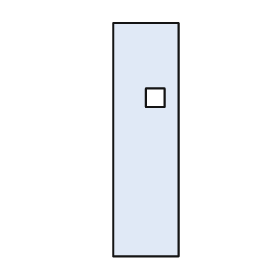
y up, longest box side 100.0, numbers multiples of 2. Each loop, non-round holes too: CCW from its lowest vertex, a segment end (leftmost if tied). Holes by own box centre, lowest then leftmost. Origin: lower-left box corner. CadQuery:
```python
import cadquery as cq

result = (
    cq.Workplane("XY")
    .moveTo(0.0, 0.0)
    .lineTo(28.0, 0.0)
    .lineTo(28.0, 100.0)
    .lineTo(0.0, 100.0)
    .close()
    .moveTo(14.0, 64.0)
    .lineTo(22.0, 64.0)
    .lineTo(22.0, 72.0)
    .lineTo(14.0, 72.0)
    .close()
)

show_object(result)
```